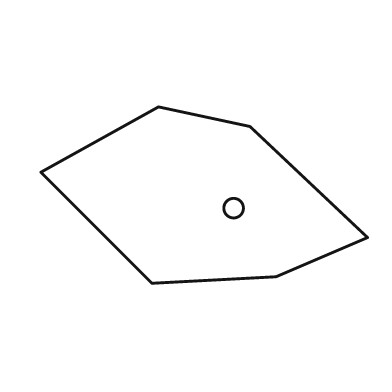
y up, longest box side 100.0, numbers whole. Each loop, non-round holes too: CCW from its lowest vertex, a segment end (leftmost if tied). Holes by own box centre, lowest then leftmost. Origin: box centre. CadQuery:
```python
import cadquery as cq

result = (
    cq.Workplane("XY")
    .moveTo(-16.0, -27.0)
    .lineTo(22.0, -25.0)
    .lineTo(50.0, -13.0)
    .lineTo(14.0, 21.0)
    .lineTo(-14.0, 27.0)
    .lineTo(-50.0, 7.0)
    .close()
    .moveTo(9.0, -4.0)
    .circle(3.0)
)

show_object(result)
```